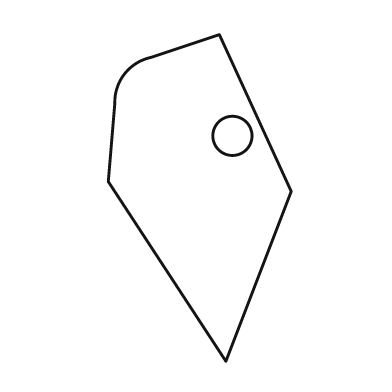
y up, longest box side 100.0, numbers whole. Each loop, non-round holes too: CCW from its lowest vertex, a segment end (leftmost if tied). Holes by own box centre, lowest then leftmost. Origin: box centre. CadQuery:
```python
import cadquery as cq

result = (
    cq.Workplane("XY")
    .moveTo(8.0, -50.0)
    .lineTo(28.0, 2.0)
    .lineTo(6.0, 50.0)
    .lineTo(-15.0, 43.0)
    .threePointArc((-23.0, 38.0), (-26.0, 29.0))
    .lineTo(-28.0, 5.0)
    .close()
    .moveTo(10.0, 19.0)
    .circle(6.0)
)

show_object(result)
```